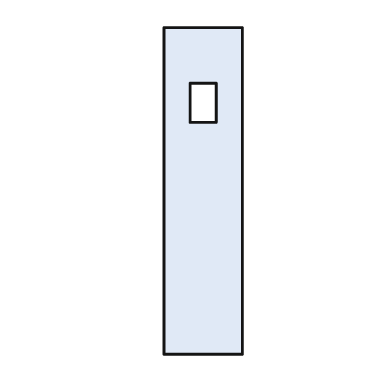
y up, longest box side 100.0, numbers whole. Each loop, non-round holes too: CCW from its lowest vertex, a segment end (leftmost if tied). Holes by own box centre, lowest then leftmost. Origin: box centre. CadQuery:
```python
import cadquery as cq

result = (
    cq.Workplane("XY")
    .moveTo(-12.0, -50.0)
    .lineTo(12.0, -50.0)
    .lineTo(12.0, 50.0)
    .lineTo(-12.0, 50.0)
    .close()
    .moveTo(-4.0, 21.0)
    .lineTo(4.0, 21.0)
    .lineTo(4.0, 33.0)
    .lineTo(-4.0, 33.0)
    .close()
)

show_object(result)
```